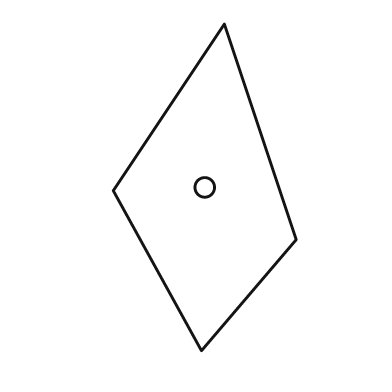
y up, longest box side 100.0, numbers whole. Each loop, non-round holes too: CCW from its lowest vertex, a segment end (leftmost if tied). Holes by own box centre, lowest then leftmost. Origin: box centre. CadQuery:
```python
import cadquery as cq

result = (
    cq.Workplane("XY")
    .moveTo(-1.0, -50.0)
    .lineTo(28.0, -16.0)
    .lineTo(6.0, 50.0)
    .lineTo(-28.0, -1.0)
    .close()
    .moveTo(0.0, 0.0)
    .circle(3.0)
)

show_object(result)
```